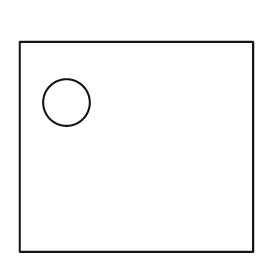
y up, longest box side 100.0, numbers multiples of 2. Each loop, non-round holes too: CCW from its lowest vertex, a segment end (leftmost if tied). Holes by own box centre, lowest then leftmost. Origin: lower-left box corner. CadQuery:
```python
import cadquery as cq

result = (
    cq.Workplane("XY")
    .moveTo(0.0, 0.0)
    .lineTo(100.0, 0.0)
    .lineTo(100.0, 90.0)
    .lineTo(0.0, 90.0)
    .close()
    .moveTo(20.0, 64.0)
    .circle(10.0)
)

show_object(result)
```